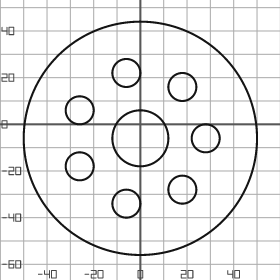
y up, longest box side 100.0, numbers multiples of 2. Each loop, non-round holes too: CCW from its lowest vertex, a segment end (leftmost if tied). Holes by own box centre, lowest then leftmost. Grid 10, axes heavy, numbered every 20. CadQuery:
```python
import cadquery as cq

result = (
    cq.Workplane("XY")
    .moveTo(0.0, -6.0)
    .circle(50.0)
    .moveTo(-6.0, -34.0)
    .circle(6.0)
    .moveTo(18.0, -28.0)
    .circle(6.0)
    .moveTo(-26.0, -18.0)
    .circle(6.0)
    .moveTo(0.0, -6.0)
    .circle(12.0)
    .moveTo(28.0, -6.0)
    .circle(6.0)
    .moveTo(-26.0, 6.0)
    .circle(6.0)
    .moveTo(18.0, 16.0)
    .circle(6.0)
    .moveTo(-6.0, 22.0)
    .circle(6.0)
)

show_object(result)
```